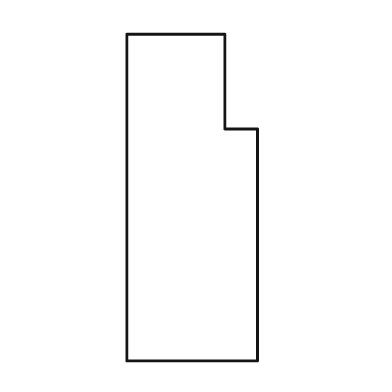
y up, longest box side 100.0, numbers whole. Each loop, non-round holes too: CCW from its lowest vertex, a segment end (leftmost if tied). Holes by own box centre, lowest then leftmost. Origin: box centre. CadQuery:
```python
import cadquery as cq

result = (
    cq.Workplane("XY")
    .moveTo(-20.0, -50.0)
    .lineTo(20.0, -50.0)
    .lineTo(20.0, 21.0)
    .lineTo(10.0, 21.0)
    .lineTo(10.0, 50.0)
    .lineTo(-20.0, 50.0)
    .close()
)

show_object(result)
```